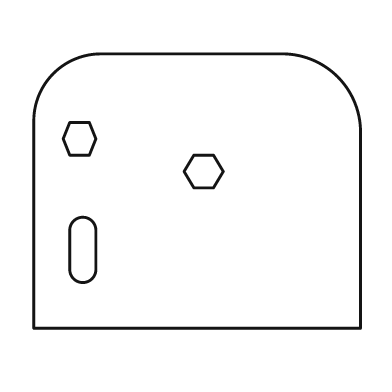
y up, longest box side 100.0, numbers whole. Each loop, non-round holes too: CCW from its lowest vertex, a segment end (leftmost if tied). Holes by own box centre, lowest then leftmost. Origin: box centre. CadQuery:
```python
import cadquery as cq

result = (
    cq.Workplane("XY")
    .moveTo(-50.0, -42.0)
    .lineTo(50.0, -42.0)
    .lineTo(50.0, 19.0)
    .threePointArc((43.0, 35.0), (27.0, 42.0))
    .lineTo(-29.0, 42.0)
    .threePointArc((-44.0, 36.0), (-50.0, 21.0))
    .close()
    .moveTo(-39.0, -24.0)
    .threePointArc((-35.0, -28.0), (-31.0, -24.0))
    .lineTo(-31.0, -12.0)
    .threePointArc((-35.0, -8.0), (-39.0, -12.0))
    .close()
    .moveTo(-1.0, 1.0)
    .lineTo(5.0, 1.0)
    .lineTo(8.0, 6.0)
    .lineTo(5.0, 11.0)
    .lineTo(-1.0, 11.0)
    .lineTo(-4.0, 6.0)
    .close()
    .moveTo(-39.0, 11.0)
    .lineTo(-33.0, 11.0)
    .lineTo(-31.0, 16.0)
    .lineTo(-33.0, 21.0)
    .lineTo(-39.0, 21.0)
    .lineTo(-41.0, 16.0)
    .close()
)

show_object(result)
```